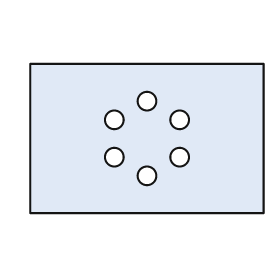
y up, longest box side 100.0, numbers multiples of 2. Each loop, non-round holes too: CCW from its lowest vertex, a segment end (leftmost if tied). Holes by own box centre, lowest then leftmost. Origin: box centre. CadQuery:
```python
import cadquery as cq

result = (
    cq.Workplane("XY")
    .moveTo(-50.0, -32.0)
    .lineTo(50.0, -32.0)
    .lineTo(50.0, 32.0)
    .lineTo(-50.0, 32.0)
    .close()
    .moveTo(0.0, -16.0)
    .circle(4.0)
    .moveTo(-14.0, -8.0)
    .circle(4.0)
    .moveTo(14.0, -8.0)
    .circle(4.0)
    .moveTo(-14.0, 8.0)
    .circle(4.0)
    .moveTo(14.0, 8.0)
    .circle(4.0)
    .moveTo(0.0, 16.0)
    .circle(4.0)
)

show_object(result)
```